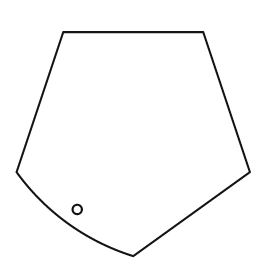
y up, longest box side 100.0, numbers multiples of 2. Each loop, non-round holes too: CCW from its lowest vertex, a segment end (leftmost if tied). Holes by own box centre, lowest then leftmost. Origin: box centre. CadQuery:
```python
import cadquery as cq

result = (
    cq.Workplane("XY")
    .moveTo(0.0, -48.0)
    .lineTo(50.0, -12.0)
    .lineTo(30.0, 48.0)
    .lineTo(-30.0, 48.0)
    .lineTo(-50.0, -12.0)
    .threePointArc((-28.0, -34.0), (0.0, -48.0))
    .close()
    .moveTo(-24.0, -28.0)
    .circle(2.0)
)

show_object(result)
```